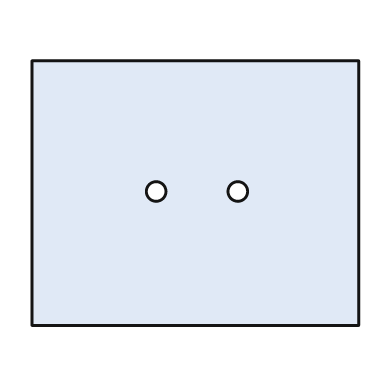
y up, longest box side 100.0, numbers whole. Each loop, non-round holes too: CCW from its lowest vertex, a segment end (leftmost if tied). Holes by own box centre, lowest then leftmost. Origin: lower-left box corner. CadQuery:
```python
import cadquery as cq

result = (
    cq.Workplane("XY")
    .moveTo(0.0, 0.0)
    .lineTo(100.0, 0.0)
    .lineTo(100.0, 81.0)
    .lineTo(0.0, 81.0)
    .close()
    .moveTo(38.0, 41.0)
    .circle(3.0)
    .moveTo(63.0, 41.0)
    .circle(3.0)
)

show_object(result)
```